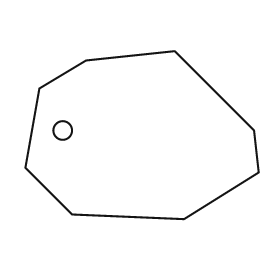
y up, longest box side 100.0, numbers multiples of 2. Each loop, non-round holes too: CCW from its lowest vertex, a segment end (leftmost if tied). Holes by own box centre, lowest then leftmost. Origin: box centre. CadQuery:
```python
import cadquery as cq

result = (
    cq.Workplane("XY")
    .moveTo(18.0, -36.0)
    .lineTo(50.0, -16.0)
    .lineTo(48.0, 2.0)
    .lineTo(14.0, 36.0)
    .lineTo(-24.0, 32.0)
    .lineTo(-44.0, 20.0)
    .lineTo(-50.0, -14.0)
    .lineTo(-30.0, -34.0)
    .close()
    .moveTo(-34.0, 2.0)
    .circle(4.0)
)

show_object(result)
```